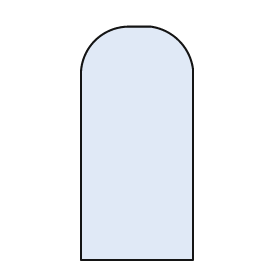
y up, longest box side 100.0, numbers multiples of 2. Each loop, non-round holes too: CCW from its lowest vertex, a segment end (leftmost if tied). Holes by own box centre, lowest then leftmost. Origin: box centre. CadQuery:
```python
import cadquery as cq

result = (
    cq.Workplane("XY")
    .moveTo(-24.0, -50.0)
    .lineTo(24.0, -50.0)
    .lineTo(24.0, 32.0)
    .threePointArc((18.0, 44.0), (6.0, 50.0))
    .lineTo(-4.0, 50.0)
    .threePointArc((-18.0, 44.0), (-24.0, 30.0))
    .close()
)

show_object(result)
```